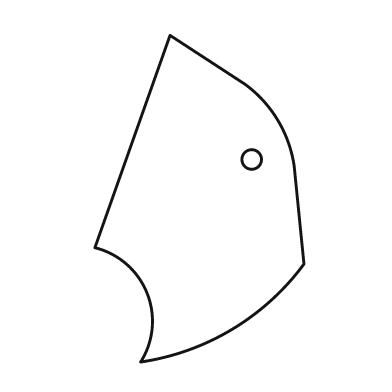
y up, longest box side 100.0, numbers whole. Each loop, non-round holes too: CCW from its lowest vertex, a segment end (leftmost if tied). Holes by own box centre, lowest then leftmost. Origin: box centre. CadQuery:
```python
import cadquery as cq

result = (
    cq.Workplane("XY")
    .moveTo(-18.0, -50.0)
    .threePointArc((10.0, -40.0), (32.0, -20.0))
    .lineTo(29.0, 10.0)
    .threePointArc((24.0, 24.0), (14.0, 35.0))
    .lineTo(-9.0, 50.0)
    .lineTo(-32.0, -15.0)
    .threePointArc((-16.0, -29.0), (-18.0, -50.0))
    .close()
    .moveTo(16.0, 12.0)
    .circle(3.0)
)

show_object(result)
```